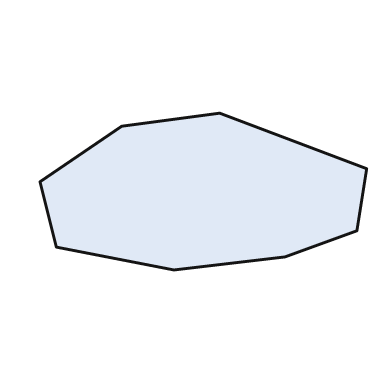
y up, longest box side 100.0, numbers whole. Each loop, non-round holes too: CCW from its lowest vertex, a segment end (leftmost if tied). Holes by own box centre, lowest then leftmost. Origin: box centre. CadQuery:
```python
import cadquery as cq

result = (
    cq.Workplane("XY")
    .moveTo(-9.0, -24.0)
    .lineTo(25.0, -20.0)
    .lineTo(47.0, -12.0)
    .lineTo(50.0, 7.0)
    .lineTo(5.0, 24.0)
    .lineTo(-25.0, 20.0)
    .lineTo(-50.0, 3.0)
    .lineTo(-45.0, -17.0)
    .close()
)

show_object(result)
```